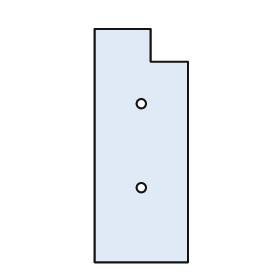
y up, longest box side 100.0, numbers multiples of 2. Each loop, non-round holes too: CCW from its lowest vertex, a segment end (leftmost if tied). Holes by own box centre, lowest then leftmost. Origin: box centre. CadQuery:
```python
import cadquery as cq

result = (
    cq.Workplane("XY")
    .moveTo(-20.0, -50.0)
    .lineTo(20.0, -50.0)
    .lineTo(20.0, 36.0)
    .lineTo(4.0, 36.0)
    .lineTo(4.0, 50.0)
    .lineTo(-20.0, 50.0)
    .close()
    .moveTo(0.0, -18.0)
    .circle(2.0)
    .moveTo(0.0, 18.0)
    .circle(2.0)
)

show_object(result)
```